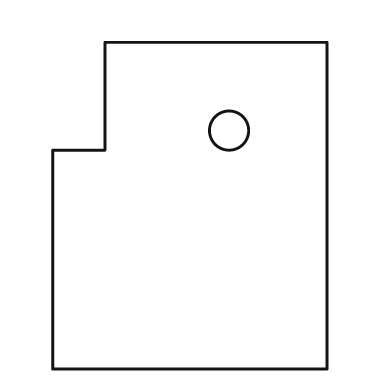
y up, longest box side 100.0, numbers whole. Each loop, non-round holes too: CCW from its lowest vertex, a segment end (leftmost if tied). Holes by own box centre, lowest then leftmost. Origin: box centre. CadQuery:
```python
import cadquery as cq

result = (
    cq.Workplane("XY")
    .moveTo(-42.0, -50.0)
    .lineTo(42.0, -50.0)
    .lineTo(42.0, 50.0)
    .lineTo(-26.0, 50.0)
    .lineTo(-26.0, 17.0)
    .lineTo(-42.0, 17.0)
    .close()
    .moveTo(12.0, 23.0)
    .circle(6.0)
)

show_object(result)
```